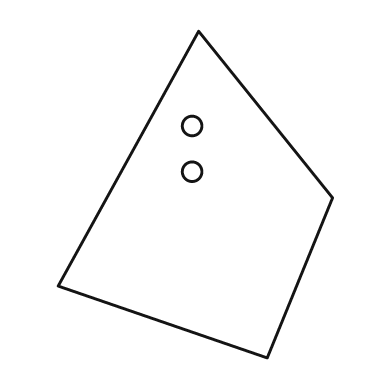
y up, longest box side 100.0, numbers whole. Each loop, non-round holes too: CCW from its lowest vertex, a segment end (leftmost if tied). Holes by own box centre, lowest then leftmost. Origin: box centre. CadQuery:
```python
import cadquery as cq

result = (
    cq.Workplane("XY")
    .moveTo(22.0, -50.0)
    .lineTo(42.0, -1.0)
    .lineTo(1.0, 50.0)
    .lineTo(-42.0, -28.0)
    .close()
    .moveTo(-1.0, 7.0)
    .circle(3.0)
    .moveTo(-1.0, 21.0)
    .circle(3.0)
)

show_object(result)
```